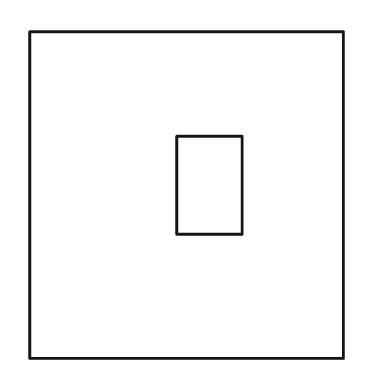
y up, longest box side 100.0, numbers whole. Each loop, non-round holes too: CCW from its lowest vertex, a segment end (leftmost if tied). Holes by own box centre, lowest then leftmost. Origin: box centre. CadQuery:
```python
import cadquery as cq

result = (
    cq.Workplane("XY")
    .moveTo(-48.0, -50.0)
    .lineTo(48.0, -50.0)
    .lineTo(48.0, 50.0)
    .lineTo(-48.0, 50.0)
    .close()
    .moveTo(-3.0, -12.0)
    .lineTo(17.0, -12.0)
    .lineTo(17.0, 18.0)
    .lineTo(-3.0, 18.0)
    .close()
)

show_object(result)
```